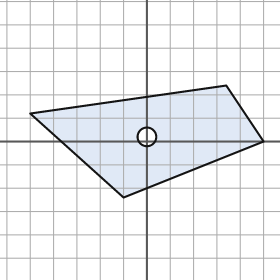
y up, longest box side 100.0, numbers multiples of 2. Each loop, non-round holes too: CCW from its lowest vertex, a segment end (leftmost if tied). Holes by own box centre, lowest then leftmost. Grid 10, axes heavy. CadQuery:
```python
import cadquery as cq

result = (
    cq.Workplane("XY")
    .moveTo(-10.0, -24.0)
    .lineTo(50.0, 0.0)
    .lineTo(34.0, 24.0)
    .lineTo(-50.0, 12.0)
    .close()
    .moveTo(0.0, 2.0)
    .circle(4.0)
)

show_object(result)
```